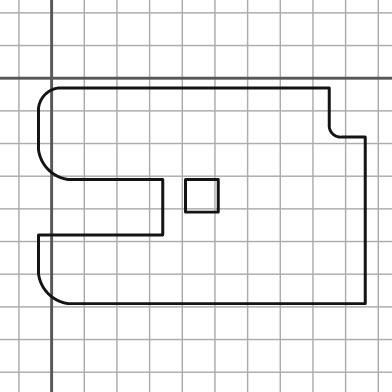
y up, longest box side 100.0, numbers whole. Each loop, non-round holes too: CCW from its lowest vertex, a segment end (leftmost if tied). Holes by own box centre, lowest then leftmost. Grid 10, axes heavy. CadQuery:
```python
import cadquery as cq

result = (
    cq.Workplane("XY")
    .moveTo(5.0, -69.0)
    .lineTo(96.0, -69.0)
    .lineTo(96.0, -18.0)
    .lineTo(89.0, -18.0)
    .threePointArc((86.0, -17.0), (85.0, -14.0))
    .lineTo(85.0, -3.0)
    .lineTo(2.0, -3.0)
    .threePointArc((-2.0, -5.0), (-4.0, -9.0))
    .lineTo(-4.0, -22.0)
    .threePointArc((-1.0, -28.0), (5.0, -31.0))
    .lineTo(34.0, -31.0)
    .lineTo(34.0, -48.0)
    .lineTo(-4.0, -48.0)
    .lineTo(-4.0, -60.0)
    .threePointArc((-1.0, -66.0), (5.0, -69.0))
    .close()
    .moveTo(41.0, -41.0)
    .lineTo(51.0, -41.0)
    .lineTo(51.0, -31.0)
    .lineTo(41.0, -31.0)
    .close()
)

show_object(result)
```